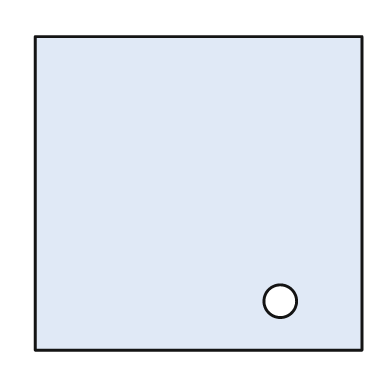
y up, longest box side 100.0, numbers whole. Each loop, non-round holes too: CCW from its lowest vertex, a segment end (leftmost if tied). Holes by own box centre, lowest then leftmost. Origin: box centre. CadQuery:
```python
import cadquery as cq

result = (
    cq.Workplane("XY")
    .moveTo(-50.0, -48.0)
    .lineTo(50.0, -48.0)
    .lineTo(50.0, 48.0)
    .lineTo(-50.0, 48.0)
    .close()
    .moveTo(25.0, -33.0)
    .circle(5.0)
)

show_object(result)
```